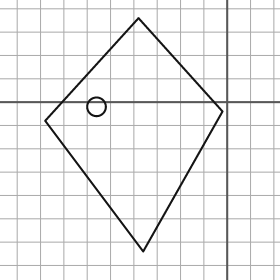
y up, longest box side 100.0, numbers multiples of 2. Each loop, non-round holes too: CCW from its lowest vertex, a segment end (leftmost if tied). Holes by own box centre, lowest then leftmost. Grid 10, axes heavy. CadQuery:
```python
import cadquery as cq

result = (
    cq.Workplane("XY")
    .moveTo(-36.0, -64.0)
    .lineTo(-2.0, -4.0)
    .lineTo(-38.0, 36.0)
    .lineTo(-78.0, -8.0)
    .close()
    .moveTo(-56.0, -2.0)
    .circle(4.0)
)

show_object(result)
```